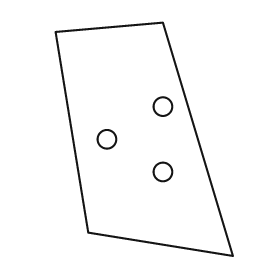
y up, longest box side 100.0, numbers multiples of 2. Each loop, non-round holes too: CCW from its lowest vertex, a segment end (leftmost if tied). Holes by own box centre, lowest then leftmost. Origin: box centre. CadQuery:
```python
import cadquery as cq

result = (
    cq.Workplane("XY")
    .moveTo(38.0, -50.0)
    .lineTo(8.0, 50.0)
    .lineTo(-38.0, 46.0)
    .lineTo(-24.0, -40.0)
    .close()
    .moveTo(8.0, -14.0)
    .circle(4.0)
    .moveTo(-16.0, 0.0)
    .circle(4.0)
    .moveTo(8.0, 14.0)
    .circle(4.0)
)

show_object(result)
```